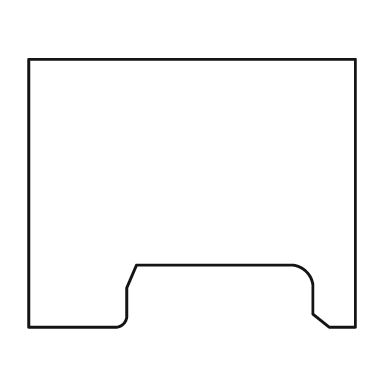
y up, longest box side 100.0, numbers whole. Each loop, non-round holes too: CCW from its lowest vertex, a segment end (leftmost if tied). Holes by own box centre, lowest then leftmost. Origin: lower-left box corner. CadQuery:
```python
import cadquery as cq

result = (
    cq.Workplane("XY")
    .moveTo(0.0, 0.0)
    .lineTo(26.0, 0.0)
    .threePointArc((29.0, 1.0), (30.0, 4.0))
    .lineTo(30.0, 12.0)
    .lineTo(33.0, 19.0)
    .lineTo(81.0, 19.0)
    .threePointArc((85.0, 17.0), (87.0, 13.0))
    .lineTo(87.0, 4.0)
    .lineTo(92.0, 0.0)
    .lineTo(100.0, 0.0)
    .lineTo(100.0, 82.0)
    .lineTo(0.0, 82.0)
    .close()
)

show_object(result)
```